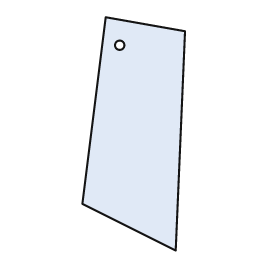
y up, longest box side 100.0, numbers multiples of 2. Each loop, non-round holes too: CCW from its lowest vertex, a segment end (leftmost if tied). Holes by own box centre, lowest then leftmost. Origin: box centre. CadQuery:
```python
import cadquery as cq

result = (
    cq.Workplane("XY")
    .moveTo(18.0, -50.0)
    .lineTo(22.0, 44.0)
    .lineTo(-12.0, 50.0)
    .lineTo(-22.0, -30.0)
    .close()
    .moveTo(-6.0, 38.0)
    .circle(2.0)
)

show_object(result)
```